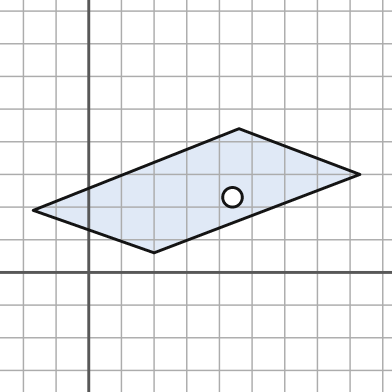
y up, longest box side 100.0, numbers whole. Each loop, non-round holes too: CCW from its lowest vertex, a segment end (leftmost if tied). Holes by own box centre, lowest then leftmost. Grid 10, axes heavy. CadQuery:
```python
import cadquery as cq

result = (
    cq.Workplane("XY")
    .moveTo(20.0, 6.0)
    .lineTo(83.0, 30.0)
    .lineTo(46.0, 44.0)
    .lineTo(-17.0, 19.0)
    .close()
    .moveTo(44.0, 23.0)
    .circle(3.0)
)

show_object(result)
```